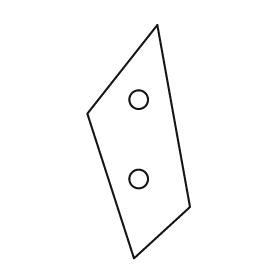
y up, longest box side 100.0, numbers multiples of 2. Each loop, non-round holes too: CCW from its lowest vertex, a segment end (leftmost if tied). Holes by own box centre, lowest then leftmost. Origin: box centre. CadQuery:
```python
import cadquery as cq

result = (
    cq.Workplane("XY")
    .moveTo(-2.0, -50.0)
    .lineTo(22.0, -28.0)
    .lineTo(8.0, 50.0)
    .lineTo(-22.0, 12.0)
    .close()
    .moveTo(0.0, -16.0)
    .circle(4.0)
    .moveTo(0.0, 18.0)
    .circle(4.0)
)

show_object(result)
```